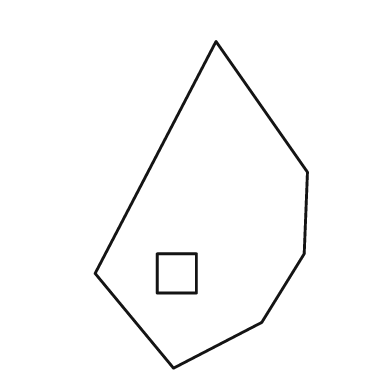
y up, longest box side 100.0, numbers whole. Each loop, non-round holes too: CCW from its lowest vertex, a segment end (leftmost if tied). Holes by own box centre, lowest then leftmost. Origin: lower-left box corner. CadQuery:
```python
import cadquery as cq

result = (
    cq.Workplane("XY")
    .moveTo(24.0, 0.0)
    .lineTo(51.0, 14.0)
    .lineTo(64.0, 35.0)
    .lineTo(65.0, 60.0)
    .lineTo(37.0, 100.0)
    .lineTo(0.0, 29.0)
    .close()
    .moveTo(19.0, 23.0)
    .lineTo(31.0, 23.0)
    .lineTo(31.0, 35.0)
    .lineTo(19.0, 35.0)
    .close()
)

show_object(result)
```